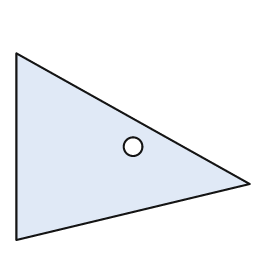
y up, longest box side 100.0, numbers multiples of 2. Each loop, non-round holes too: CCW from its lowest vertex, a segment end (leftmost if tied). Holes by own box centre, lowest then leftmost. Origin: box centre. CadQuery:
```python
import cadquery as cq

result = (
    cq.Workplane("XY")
    .moveTo(-50.0, -40.0)
    .lineTo(50.0, -16.0)
    .lineTo(-50.0, 40.0)
    .close()
    .moveTo(0.0, 0.0)
    .circle(4.0)
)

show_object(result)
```